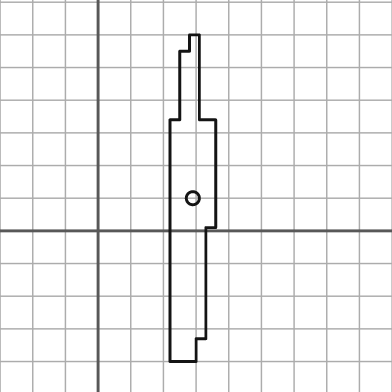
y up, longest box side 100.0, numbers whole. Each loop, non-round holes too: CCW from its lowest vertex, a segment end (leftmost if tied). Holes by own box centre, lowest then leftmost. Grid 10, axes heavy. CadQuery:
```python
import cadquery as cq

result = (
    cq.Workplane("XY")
    .moveTo(22.0, -40.0)
    .lineTo(30.0, -40.0)
    .lineTo(30.0, -33.0)
    .lineTo(33.0, -33.0)
    .lineTo(33.0, 1.0)
    .lineTo(36.0, 1.0)
    .lineTo(36.0, 34.0)
    .lineTo(31.0, 34.0)
    .lineTo(31.0, 60.0)
    .lineTo(28.0, 60.0)
    .lineTo(28.0, 55.0)
    .lineTo(25.0, 55.0)
    .lineTo(25.0, 34.0)
    .lineTo(22.0, 34.0)
    .close()
    .moveTo(29.0, 10.0)
    .circle(2.0)
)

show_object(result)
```